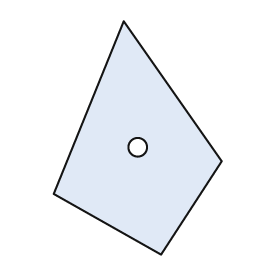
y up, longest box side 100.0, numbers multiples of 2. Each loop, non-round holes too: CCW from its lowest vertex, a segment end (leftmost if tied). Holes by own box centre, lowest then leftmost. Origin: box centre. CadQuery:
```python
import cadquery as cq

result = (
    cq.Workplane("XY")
    .moveTo(10.0, -50.0)
    .lineTo(36.0, -10.0)
    .lineTo(-6.0, 50.0)
    .lineTo(-36.0, -24.0)
    .close()
    .moveTo(0.0, -4.0)
    .circle(4.0)
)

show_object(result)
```